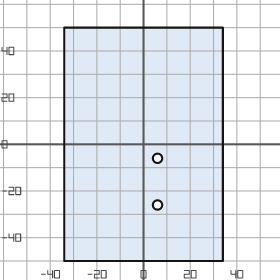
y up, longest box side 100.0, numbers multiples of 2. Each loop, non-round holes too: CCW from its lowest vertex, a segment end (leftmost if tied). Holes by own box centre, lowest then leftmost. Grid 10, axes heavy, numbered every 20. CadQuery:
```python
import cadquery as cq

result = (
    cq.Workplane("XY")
    .moveTo(-34.0, -50.0)
    .lineTo(34.0, -50.0)
    .lineTo(34.0, 50.0)
    .lineTo(-34.0, 50.0)
    .close()
    .moveTo(6.0, -26.0)
    .circle(2.0)
    .moveTo(6.0, -6.0)
    .circle(2.0)
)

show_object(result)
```